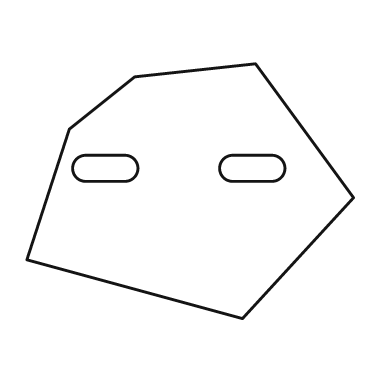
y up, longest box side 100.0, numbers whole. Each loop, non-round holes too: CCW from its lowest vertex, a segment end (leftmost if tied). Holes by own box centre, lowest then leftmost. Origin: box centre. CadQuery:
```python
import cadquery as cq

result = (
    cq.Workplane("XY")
    .moveTo(16.0, -39.0)
    .lineTo(50.0, -2.0)
    .lineTo(20.0, 39.0)
    .lineTo(-17.0, 35.0)
    .lineTo(-37.0, 19.0)
    .lineTo(-50.0, -21.0)
    .close()
    .moveTo(-32.0, 3.0)
    .lineTo(-20.0, 3.0)
    .threePointArc((-16.0, 7.0), (-20.0, 11.0))
    .lineTo(-32.0, 11.0)
    .threePointArc((-36.0, 7.0), (-32.0, 3.0))
    .close()
    .moveTo(13.0, 3.0)
    .lineTo(25.0, 3.0)
    .threePointArc((29.0, 7.0), (25.0, 11.0))
    .lineTo(13.0, 11.0)
    .threePointArc((9.0, 7.0), (13.0, 3.0))
    .close()
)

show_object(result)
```